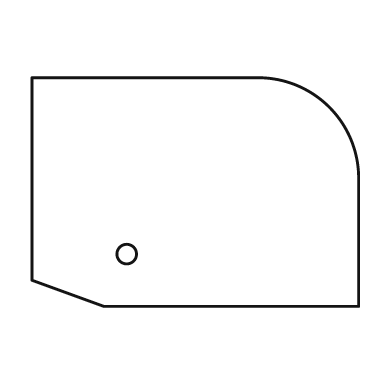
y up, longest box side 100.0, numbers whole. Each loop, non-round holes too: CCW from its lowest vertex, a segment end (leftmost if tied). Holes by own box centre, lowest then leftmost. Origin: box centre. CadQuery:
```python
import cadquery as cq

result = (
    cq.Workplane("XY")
    .moveTo(-28.0, -35.0)
    .lineTo(50.0, -35.0)
    .lineTo(50.0, 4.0)
    .threePointArc((41.0, 26.0), (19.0, 35.0))
    .lineTo(-50.0, 35.0)
    .lineTo(-50.0, -27.0)
    .close()
    .moveTo(-21.0, -19.0)
    .circle(3.0)
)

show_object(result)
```